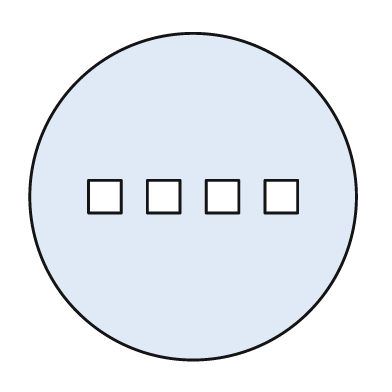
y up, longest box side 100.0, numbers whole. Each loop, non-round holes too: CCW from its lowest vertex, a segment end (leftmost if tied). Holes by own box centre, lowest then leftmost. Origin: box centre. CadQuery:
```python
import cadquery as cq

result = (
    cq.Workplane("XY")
    .moveTo(0.0, 0.0)
    .circle(50.0)
    .moveTo(-32.0, -5.0)
    .lineTo(-22.0, -5.0)
    .lineTo(-22.0, 5.0)
    .lineTo(-32.0, 5.0)
    .close()
    .moveTo(-14.0, -5.0)
    .lineTo(-4.0, -5.0)
    .lineTo(-4.0, 5.0)
    .lineTo(-14.0, 5.0)
    .close()
    .moveTo(4.0, -5.0)
    .lineTo(14.0, -5.0)
    .lineTo(14.0, 5.0)
    .lineTo(4.0, 5.0)
    .close()
    .moveTo(22.0, -5.0)
    .lineTo(32.0, -5.0)
    .lineTo(32.0, 5.0)
    .lineTo(22.0, 5.0)
    .close()
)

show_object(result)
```